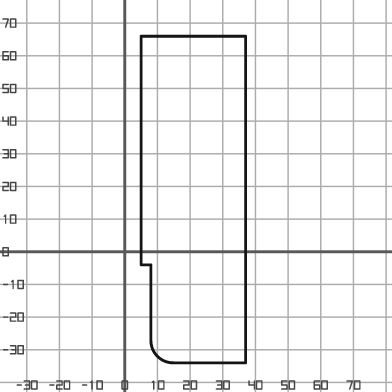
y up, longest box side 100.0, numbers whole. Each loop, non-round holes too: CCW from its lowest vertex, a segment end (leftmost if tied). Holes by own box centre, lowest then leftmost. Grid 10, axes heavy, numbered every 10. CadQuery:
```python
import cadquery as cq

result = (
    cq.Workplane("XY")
    .moveTo(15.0, -34.0)
    .lineTo(37.0, -34.0)
    .lineTo(37.0, 66.0)
    .lineTo(5.0, 66.0)
    .lineTo(5.0, -4.0)
    .lineTo(8.0, -4.0)
    .lineTo(8.0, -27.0)
    .threePointArc((10.0, -32.0), (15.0, -34.0))
    .close()
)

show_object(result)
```